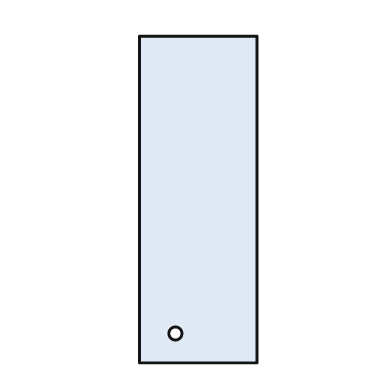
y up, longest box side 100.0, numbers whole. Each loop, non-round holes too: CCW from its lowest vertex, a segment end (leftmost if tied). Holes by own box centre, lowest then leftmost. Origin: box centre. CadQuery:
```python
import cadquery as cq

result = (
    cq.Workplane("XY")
    .moveTo(-18.0, -50.0)
    .lineTo(18.0, -50.0)
    .lineTo(18.0, 50.0)
    .lineTo(-18.0, 50.0)
    .close()
    .moveTo(-7.0, -41.0)
    .circle(2.0)
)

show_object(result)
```